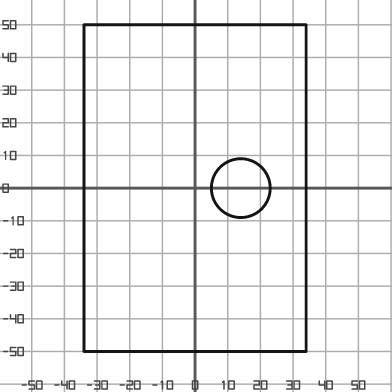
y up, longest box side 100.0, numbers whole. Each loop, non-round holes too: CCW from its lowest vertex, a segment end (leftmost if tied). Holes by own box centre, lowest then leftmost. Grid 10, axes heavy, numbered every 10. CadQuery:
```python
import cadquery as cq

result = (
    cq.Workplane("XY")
    .moveTo(-34.0, -50.0)
    .lineTo(34.0, -50.0)
    .lineTo(34.0, 50.0)
    .lineTo(-34.0, 50.0)
    .close()
    .moveTo(14.0, 0.0)
    .circle(9.0)
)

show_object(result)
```